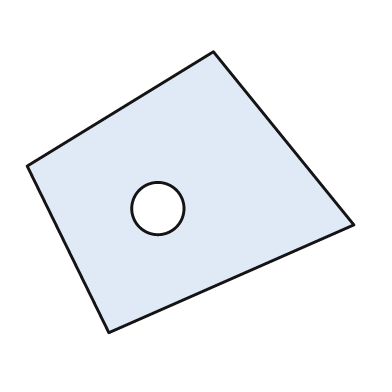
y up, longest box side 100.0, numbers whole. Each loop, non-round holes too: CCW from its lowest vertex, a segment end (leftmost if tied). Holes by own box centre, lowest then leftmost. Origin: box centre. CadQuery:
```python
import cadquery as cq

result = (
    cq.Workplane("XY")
    .moveTo(-25.0, -43.0)
    .lineTo(50.0, -10.0)
    .lineTo(7.0, 43.0)
    .lineTo(-50.0, 8.0)
    .close()
    .moveTo(-10.0, -5.0)
    .circle(8.0)
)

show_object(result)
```